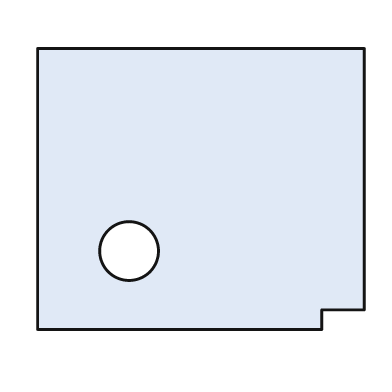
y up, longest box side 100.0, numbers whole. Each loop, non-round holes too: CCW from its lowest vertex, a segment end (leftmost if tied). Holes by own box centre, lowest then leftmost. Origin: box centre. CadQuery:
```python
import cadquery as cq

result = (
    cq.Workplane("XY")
    .moveTo(-50.0, -43.0)
    .lineTo(37.0, -43.0)
    .lineTo(37.0, -37.0)
    .lineTo(50.0, -37.0)
    .lineTo(50.0, 43.0)
    .lineTo(-50.0, 43.0)
    .close()
    .moveTo(-22.0, -19.0)
    .circle(9.0)
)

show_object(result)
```